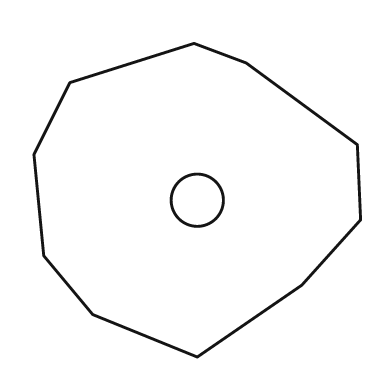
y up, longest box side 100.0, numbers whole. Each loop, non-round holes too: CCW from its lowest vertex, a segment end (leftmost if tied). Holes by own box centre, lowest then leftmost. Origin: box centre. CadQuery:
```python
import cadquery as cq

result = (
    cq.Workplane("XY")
    .moveTo(0.0, -48.0)
    .lineTo(32.0, -26.0)
    .lineTo(50.0, -6.0)
    .lineTo(49.0, 17.0)
    .lineTo(15.0, 42.0)
    .lineTo(-1.0, 48.0)
    .lineTo(-39.0, 36.0)
    .lineTo(-50.0, 14.0)
    .lineTo(-47.0, -17.0)
    .lineTo(-32.0, -35.0)
    .close()
    .moveTo(0.0, 0.0)
    .circle(8.0)
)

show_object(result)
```